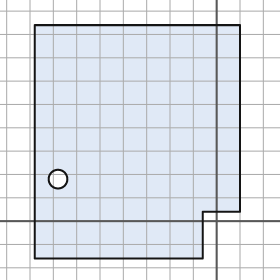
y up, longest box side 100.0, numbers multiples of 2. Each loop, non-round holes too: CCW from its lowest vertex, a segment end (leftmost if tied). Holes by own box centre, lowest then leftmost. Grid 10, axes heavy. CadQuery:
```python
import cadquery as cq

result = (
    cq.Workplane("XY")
    .moveTo(-78.0, -16.0)
    .lineTo(-6.0, -16.0)
    .lineTo(-6.0, 4.0)
    .lineTo(10.0, 4.0)
    .lineTo(10.0, 84.0)
    .lineTo(-78.0, 84.0)
    .close()
    .moveTo(-68.0, 18.0)
    .circle(4.0)
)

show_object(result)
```